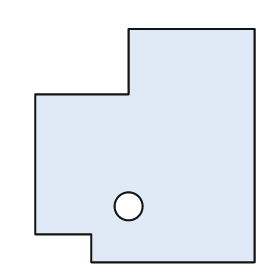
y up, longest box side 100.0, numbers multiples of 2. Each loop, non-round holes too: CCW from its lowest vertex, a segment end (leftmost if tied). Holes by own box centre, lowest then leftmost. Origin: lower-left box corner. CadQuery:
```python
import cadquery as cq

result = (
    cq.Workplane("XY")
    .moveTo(24.0, 0.0)
    .lineTo(94.0, 0.0)
    .lineTo(94.0, 100.0)
    .lineTo(40.0, 100.0)
    .lineTo(40.0, 72.0)
    .lineTo(0.0, 72.0)
    .lineTo(0.0, 12.0)
    .lineTo(24.0, 12.0)
    .close()
    .moveTo(40.0, 24.0)
    .circle(6.0)
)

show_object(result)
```